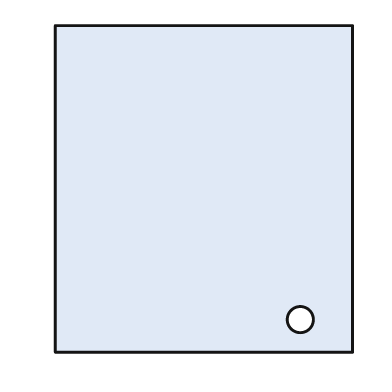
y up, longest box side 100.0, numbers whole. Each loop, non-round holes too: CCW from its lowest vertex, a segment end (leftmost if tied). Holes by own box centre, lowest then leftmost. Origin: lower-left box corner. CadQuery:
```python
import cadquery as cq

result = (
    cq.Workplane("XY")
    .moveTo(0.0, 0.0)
    .lineTo(91.0, 0.0)
    .lineTo(91.0, 100.0)
    .lineTo(0.0, 100.0)
    .close()
    .moveTo(75.0, 10.0)
    .circle(4.0)
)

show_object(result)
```